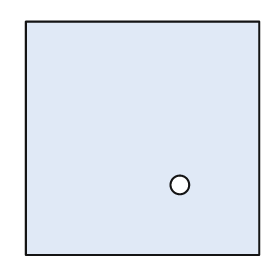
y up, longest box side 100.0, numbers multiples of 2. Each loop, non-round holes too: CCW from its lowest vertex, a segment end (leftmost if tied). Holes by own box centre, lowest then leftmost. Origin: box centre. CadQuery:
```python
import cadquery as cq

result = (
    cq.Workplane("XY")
    .moveTo(-50.0, -50.0)
    .lineTo(50.0, -50.0)
    .lineTo(50.0, 50.0)
    .lineTo(-50.0, 50.0)
    .close()
    .moveTo(16.0, -20.0)
    .circle(4.0)
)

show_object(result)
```